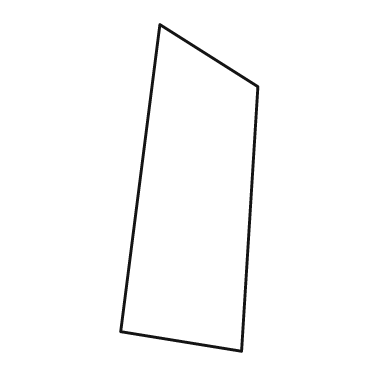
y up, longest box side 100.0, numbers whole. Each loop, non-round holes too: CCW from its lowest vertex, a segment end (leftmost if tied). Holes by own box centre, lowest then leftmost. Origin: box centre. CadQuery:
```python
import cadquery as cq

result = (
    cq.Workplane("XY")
    .moveTo(16.0, -50.0)
    .lineTo(21.0, 31.0)
    .lineTo(-9.0, 50.0)
    .lineTo(-21.0, -44.0)
    .close()
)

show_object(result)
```